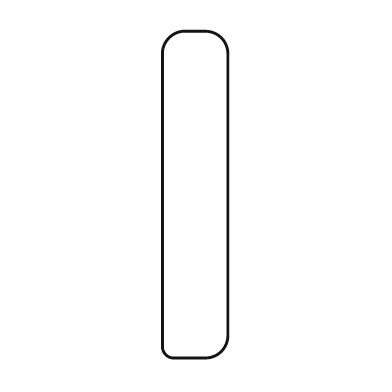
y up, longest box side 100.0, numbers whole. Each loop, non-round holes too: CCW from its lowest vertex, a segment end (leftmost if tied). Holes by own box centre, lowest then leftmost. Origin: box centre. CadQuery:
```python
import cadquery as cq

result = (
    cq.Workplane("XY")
    .moveTo(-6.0, -50.0)
    .lineTo(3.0, -50.0)
    .threePointArc((8.0, -48.0), (10.0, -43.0))
    .lineTo(10.0, 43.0)
    .threePointArc((8.0, 48.0), (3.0, 50.0))
    .lineTo(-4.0, 50.0)
    .threePointArc((-8.0, 48.0), (-10.0, 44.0))
    .lineTo(-10.0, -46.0)
    .threePointArc((-9.0, -49.0), (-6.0, -50.0))
    .close()
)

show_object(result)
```